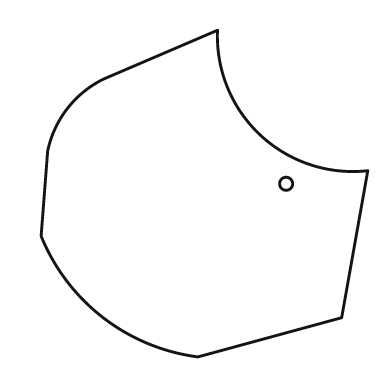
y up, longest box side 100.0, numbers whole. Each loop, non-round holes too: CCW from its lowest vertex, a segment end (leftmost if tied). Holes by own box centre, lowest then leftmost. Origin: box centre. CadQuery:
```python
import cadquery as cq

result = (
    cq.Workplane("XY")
    .moveTo(-2.0, -50.0)
    .lineTo(42.0, -38.0)
    .lineTo(50.0, 7.0)
    .threePointArc((17.0, 18.0), (4.0, 50.0))
    .lineTo(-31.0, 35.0)
    .threePointArc((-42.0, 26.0), (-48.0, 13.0))
    .lineTo(-50.0, -13.0)
    .threePointArc((-31.0, -38.0), (-2.0, -50.0))
    .close()
    .moveTo(25.0, 3.0)
    .circle(2.0)
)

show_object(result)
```